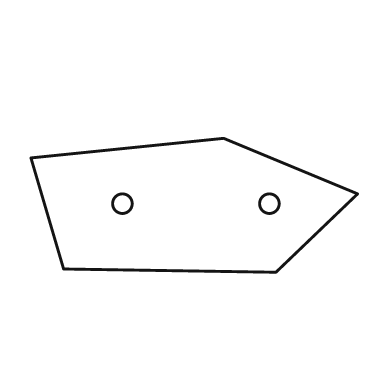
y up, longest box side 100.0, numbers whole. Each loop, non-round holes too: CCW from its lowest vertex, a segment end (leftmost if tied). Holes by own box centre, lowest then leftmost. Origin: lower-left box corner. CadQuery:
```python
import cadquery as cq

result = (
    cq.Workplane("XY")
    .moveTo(75.0, 0.0)
    .lineTo(100.0, 24.0)
    .lineTo(59.0, 41.0)
    .lineTo(0.0, 35.0)
    .lineTo(10.0, 1.0)
    .close()
    .moveTo(28.0, 21.0)
    .circle(3.0)
    .moveTo(73.0, 21.0)
    .circle(3.0)
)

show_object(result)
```